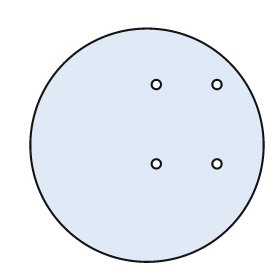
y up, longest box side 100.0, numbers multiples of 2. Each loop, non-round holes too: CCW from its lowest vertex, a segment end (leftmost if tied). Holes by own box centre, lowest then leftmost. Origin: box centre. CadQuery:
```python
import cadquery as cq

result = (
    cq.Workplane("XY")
    .moveTo(0.0, 0.0)
    .circle(50.0)
    .moveTo(4.0, -8.0)
    .circle(2.0)
    .moveTo(30.0, -8.0)
    .circle(2.0)
    .moveTo(4.0, 26.0)
    .circle(2.0)
    .moveTo(30.0, 26.0)
    .circle(2.0)
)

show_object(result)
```